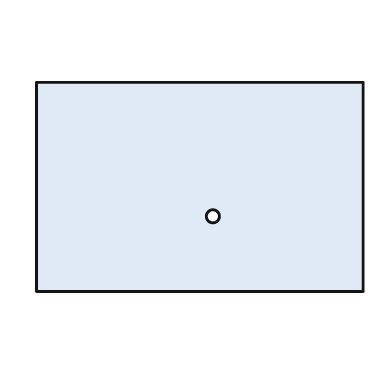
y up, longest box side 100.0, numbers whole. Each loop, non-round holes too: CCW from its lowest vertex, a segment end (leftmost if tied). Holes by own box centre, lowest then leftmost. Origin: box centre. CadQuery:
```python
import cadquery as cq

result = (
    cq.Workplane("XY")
    .moveTo(-50.0, -32.0)
    .lineTo(50.0, -32.0)
    .lineTo(50.0, 32.0)
    .lineTo(-50.0, 32.0)
    .close()
    .moveTo(4.0, -9.0)
    .circle(2.0)
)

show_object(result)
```